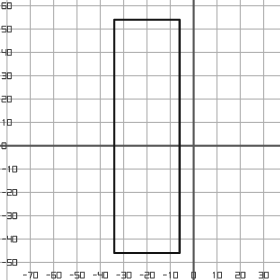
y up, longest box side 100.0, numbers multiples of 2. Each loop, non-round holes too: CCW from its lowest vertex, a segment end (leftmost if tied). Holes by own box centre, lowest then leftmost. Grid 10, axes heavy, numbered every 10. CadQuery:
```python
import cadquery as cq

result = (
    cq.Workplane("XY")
    .moveTo(-34.0, -46.0)
    .lineTo(-6.0, -46.0)
    .lineTo(-6.0, 54.0)
    .lineTo(-34.0, 54.0)
    .close()
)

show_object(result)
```